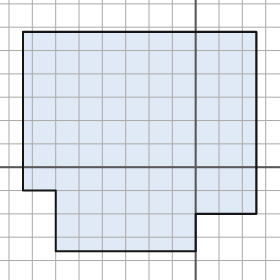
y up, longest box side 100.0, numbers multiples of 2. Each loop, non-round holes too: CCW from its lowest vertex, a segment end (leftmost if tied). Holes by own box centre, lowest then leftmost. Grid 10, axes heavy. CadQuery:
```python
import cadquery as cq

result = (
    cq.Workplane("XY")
    .moveTo(-60.0, -36.0)
    .lineTo(0.0, -36.0)
    .lineTo(0.0, -20.0)
    .lineTo(26.0, -20.0)
    .lineTo(26.0, 58.0)
    .lineTo(-74.0, 58.0)
    .lineTo(-74.0, -10.0)
    .lineTo(-60.0, -10.0)
    .close()
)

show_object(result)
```